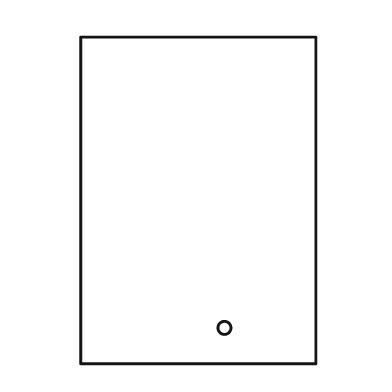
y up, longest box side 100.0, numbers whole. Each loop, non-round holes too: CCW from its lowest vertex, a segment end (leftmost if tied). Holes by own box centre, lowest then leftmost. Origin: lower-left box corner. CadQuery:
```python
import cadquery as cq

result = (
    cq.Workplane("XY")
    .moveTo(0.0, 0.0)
    .lineTo(72.0, 0.0)
    .lineTo(72.0, 100.0)
    .lineTo(0.0, 100.0)
    .close()
    .moveTo(44.0, 11.0)
    .circle(2.0)
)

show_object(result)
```